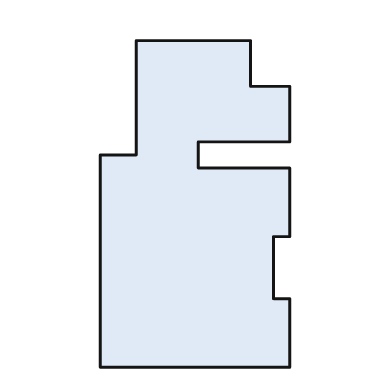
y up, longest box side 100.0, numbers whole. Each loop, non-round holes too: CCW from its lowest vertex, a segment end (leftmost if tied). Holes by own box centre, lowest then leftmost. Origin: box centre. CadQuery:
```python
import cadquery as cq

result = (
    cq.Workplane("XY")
    .moveTo(-29.0, -50.0)
    .lineTo(29.0, -50.0)
    .lineTo(29.0, -29.0)
    .lineTo(24.0, -29.0)
    .lineTo(24.0, -10.0)
    .lineTo(29.0, -10.0)
    .lineTo(29.0, 11.0)
    .lineTo(1.0, 11.0)
    .lineTo(1.0, 19.0)
    .lineTo(29.0, 19.0)
    .lineTo(29.0, 36.0)
    .lineTo(17.0, 36.0)
    .lineTo(17.0, 50.0)
    .lineTo(-18.0, 50.0)
    .lineTo(-18.0, 15.0)
    .lineTo(-29.0, 15.0)
    .close()
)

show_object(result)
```